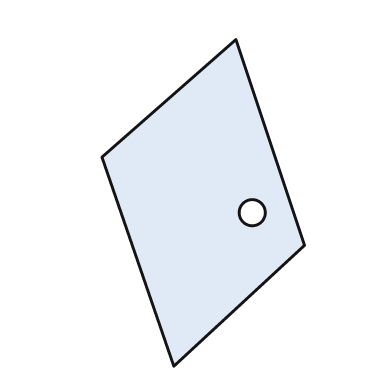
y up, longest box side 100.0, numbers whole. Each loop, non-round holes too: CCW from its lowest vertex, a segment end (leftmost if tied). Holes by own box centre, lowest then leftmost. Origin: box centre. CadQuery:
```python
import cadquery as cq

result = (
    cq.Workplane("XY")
    .moveTo(-9.0, -50.0)
    .lineTo(31.0, -13.0)
    .lineTo(10.0, 50.0)
    .lineTo(-31.0, 14.0)
    .close()
    .moveTo(15.0, -3.0)
    .circle(4.0)
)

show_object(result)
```